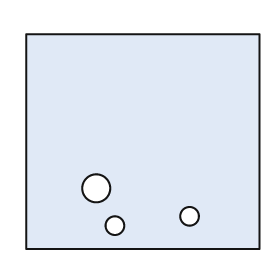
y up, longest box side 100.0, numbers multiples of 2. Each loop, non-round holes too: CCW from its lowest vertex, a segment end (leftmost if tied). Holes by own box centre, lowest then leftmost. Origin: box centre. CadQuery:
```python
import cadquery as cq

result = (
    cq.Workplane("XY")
    .moveTo(-50.0, -46.0)
    .lineTo(50.0, -46.0)
    .lineTo(50.0, 46.0)
    .lineTo(-50.0, 46.0)
    .close()
    .moveTo(-12.0, -36.0)
    .circle(4.0)
    .moveTo(20.0, -32.0)
    .circle(4.0)
    .moveTo(-20.0, -20.0)
    .circle(6.0)
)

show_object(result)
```